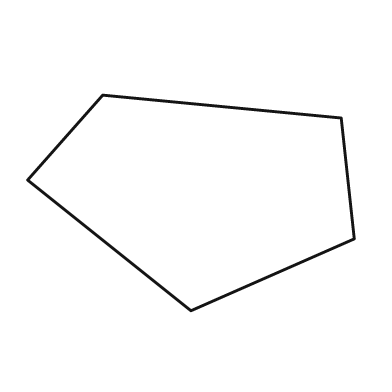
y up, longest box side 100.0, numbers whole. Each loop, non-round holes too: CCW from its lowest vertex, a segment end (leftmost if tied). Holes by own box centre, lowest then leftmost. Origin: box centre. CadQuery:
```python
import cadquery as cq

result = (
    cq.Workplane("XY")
    .moveTo(0.0, -33.0)
    .lineTo(50.0, -11.0)
    .lineTo(46.0, 26.0)
    .lineTo(-27.0, 33.0)
    .lineTo(-50.0, 7.0)
    .close()
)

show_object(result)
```